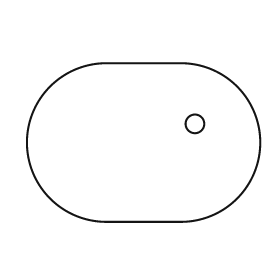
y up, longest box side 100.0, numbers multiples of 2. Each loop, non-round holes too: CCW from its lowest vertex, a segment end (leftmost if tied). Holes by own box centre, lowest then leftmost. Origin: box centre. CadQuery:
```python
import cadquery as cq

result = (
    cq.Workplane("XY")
    .moveTo(-16.0, -34.0)
    .lineTo(16.0, -34.0)
    .threePointArc((50.0, 0.0), (16.0, 34.0))
    .lineTo(-16.0, 34.0)
    .threePointArc((-50.0, 0.0), (-16.0, -34.0))
    .close()
    .moveTo(22.0, 8.0)
    .circle(4.0)
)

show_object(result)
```